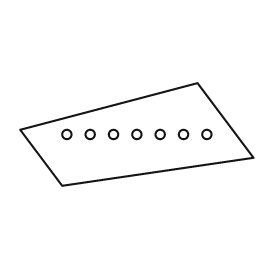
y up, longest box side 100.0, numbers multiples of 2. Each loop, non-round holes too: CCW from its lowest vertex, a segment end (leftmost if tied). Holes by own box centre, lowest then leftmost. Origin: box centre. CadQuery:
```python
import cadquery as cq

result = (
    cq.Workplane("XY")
    .moveTo(-32.0, -22.0)
    .lineTo(50.0, -10.0)
    .lineTo(26.0, 22.0)
    .lineTo(-50.0, 2.0)
    .close()
    .moveTo(-30.0, 0.0)
    .circle(2.0)
    .moveTo(-20.0, 0.0)
    .circle(2.0)
    .moveTo(-10.0, 0.0)
    .circle(2.0)
    .moveTo(0.0, 0.0)
    .circle(2.0)
    .moveTo(10.0, 0.0)
    .circle(2.0)
    .moveTo(20.0, 0.0)
    .circle(2.0)
    .moveTo(30.0, 0.0)
    .circle(2.0)
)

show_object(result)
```